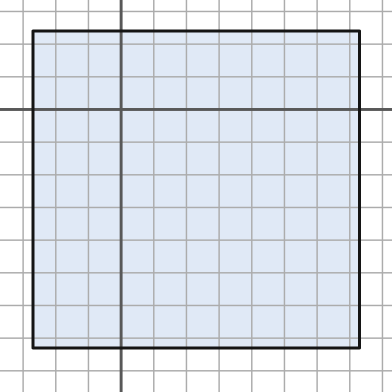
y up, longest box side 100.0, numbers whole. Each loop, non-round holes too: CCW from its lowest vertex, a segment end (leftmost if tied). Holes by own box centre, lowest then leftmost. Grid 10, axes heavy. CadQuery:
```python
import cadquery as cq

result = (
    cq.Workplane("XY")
    .moveTo(-27.0, -73.0)
    .lineTo(73.0, -73.0)
    .lineTo(73.0, 24.0)
    .lineTo(-27.0, 24.0)
    .close()
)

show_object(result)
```